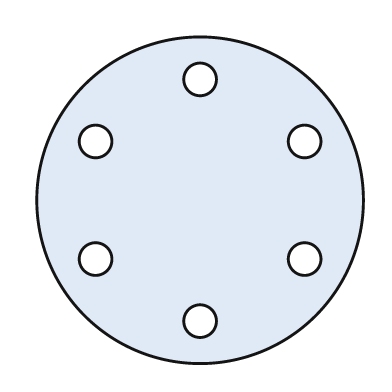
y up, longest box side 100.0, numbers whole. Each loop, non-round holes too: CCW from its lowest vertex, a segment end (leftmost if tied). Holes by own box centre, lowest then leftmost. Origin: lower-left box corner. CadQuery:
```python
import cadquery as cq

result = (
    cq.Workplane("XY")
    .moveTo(50.0, 50.0)
    .circle(50.0)
    .moveTo(50.0, 13.0)
    .circle(5.0)
    .moveTo(18.0, 32.0)
    .circle(5.0)
    .moveTo(82.0, 32.0)
    .circle(5.0)
    .moveTo(18.0, 68.0)
    .circle(5.0)
    .moveTo(82.0, 68.0)
    .circle(5.0)
    .moveTo(50.0, 87.0)
    .circle(5.0)
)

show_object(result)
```